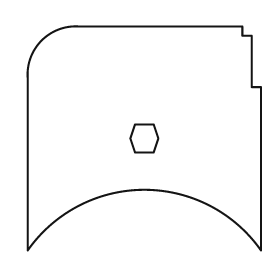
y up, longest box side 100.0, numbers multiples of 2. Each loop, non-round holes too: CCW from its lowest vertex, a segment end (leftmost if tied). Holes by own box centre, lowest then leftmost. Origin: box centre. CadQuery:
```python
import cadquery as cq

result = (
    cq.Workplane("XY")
    .moveTo(-50.0, -48.0)
    .threePointArc((0.0, -22.0), (50.0, -48.0))
    .lineTo(50.0, 22.0)
    .lineTo(46.0, 22.0)
    .lineTo(46.0, 44.0)
    .lineTo(42.0, 44.0)
    .lineTo(42.0, 48.0)
    .lineTo(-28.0, 48.0)
    .threePointArc((-44.0, 42.0), (-50.0, 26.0))
    .close()
    .moveTo(-4.0, -6.0)
    .lineTo(4.0, -6.0)
    .lineTo(6.0, 0.0)
    .lineTo(4.0, 6.0)
    .lineTo(-4.0, 6.0)
    .lineTo(-6.0, 0.0)
    .close()
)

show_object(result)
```